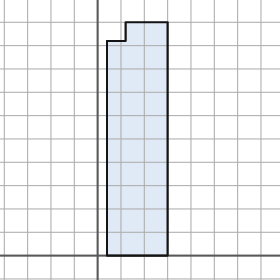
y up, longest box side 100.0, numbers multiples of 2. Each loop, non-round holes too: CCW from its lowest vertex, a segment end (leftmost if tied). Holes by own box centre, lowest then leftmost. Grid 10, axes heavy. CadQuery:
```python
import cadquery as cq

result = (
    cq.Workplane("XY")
    .moveTo(4.0, 0.0)
    .lineTo(30.0, 0.0)
    .lineTo(30.0, 100.0)
    .lineTo(12.0, 100.0)
    .lineTo(12.0, 92.0)
    .lineTo(4.0, 92.0)
    .close()
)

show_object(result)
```